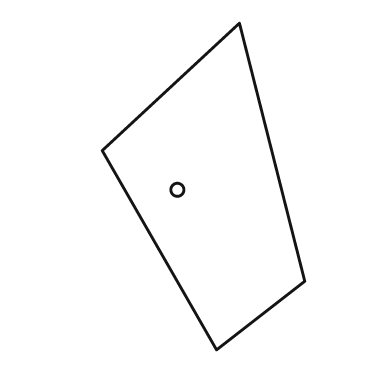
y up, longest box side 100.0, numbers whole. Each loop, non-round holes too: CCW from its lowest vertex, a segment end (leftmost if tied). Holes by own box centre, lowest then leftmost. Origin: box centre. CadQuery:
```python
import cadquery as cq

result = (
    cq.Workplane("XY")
    .moveTo(4.0, -50.0)
    .lineTo(31.0, -29.0)
    .lineTo(11.0, 50.0)
    .lineTo(-31.0, 11.0)
    .close()
    .moveTo(-8.0, -1.0)
    .circle(2.0)
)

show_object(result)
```